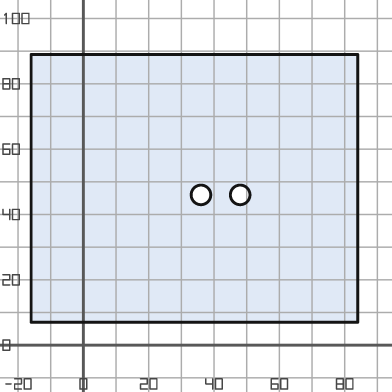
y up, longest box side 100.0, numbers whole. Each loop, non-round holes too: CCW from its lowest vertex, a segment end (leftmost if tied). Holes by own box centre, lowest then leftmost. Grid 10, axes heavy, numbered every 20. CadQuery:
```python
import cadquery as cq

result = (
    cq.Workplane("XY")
    .moveTo(-16.0, 7.0)
    .lineTo(84.0, 7.0)
    .lineTo(84.0, 89.0)
    .lineTo(-16.0, 89.0)
    .close()
    .moveTo(36.0, 46.0)
    .circle(3.0)
    .moveTo(48.0, 46.0)
    .circle(3.0)
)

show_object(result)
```